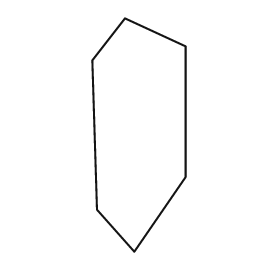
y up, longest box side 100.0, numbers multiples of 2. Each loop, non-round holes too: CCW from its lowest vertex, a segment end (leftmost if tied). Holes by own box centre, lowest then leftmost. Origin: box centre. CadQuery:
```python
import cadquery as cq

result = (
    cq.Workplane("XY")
    .moveTo(-2.0, -50.0)
    .lineTo(20.0, -18.0)
    .lineTo(20.0, 38.0)
    .lineTo(-6.0, 50.0)
    .lineTo(-20.0, 32.0)
    .lineTo(-18.0, -32.0)
    .close()
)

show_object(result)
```